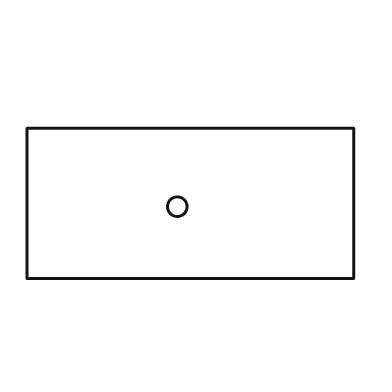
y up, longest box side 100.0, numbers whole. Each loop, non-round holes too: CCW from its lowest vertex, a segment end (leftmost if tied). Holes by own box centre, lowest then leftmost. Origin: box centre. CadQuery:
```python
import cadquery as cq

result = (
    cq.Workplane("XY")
    .moveTo(-50.0, -23.0)
    .lineTo(50.0, -23.0)
    .lineTo(50.0, 23.0)
    .lineTo(-50.0, 23.0)
    .close()
    .moveTo(-4.0, -1.0)
    .circle(3.0)
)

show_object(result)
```